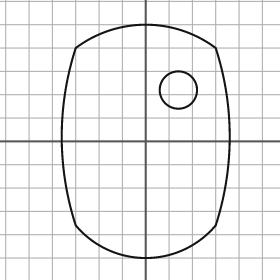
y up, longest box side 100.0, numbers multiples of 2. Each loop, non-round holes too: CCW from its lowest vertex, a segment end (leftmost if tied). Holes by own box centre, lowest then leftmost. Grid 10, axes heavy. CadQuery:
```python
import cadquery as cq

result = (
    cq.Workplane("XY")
    .moveTo(-30.0, -36.0)
    .threePointArc((0.0, -50.0), (30.0, -36.0))
    .threePointArc((36.0, 2.0), (30.0, 40.0))
    .threePointArc((0.0, 50.0), (-30.0, 40.0))
    .threePointArc((-36.0, 2.0), (-30.0, -36.0))
    .close()
    .moveTo(14.0, 22.0)
    .circle(8.0)
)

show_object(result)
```